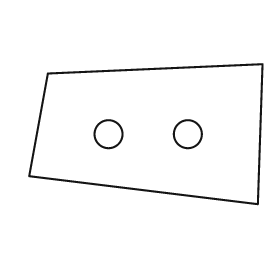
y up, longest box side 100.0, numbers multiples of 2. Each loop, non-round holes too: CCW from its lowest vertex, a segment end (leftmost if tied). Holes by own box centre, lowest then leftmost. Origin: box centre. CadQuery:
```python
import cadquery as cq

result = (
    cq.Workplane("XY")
    .moveTo(48.0, -30.0)
    .lineTo(50.0, 30.0)
    .lineTo(-42.0, 26.0)
    .lineTo(-50.0, -18.0)
    .close()
    .moveTo(-16.0, 0.0)
    .circle(6.0)
    .moveTo(18.0, 0.0)
    .circle(6.0)
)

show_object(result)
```